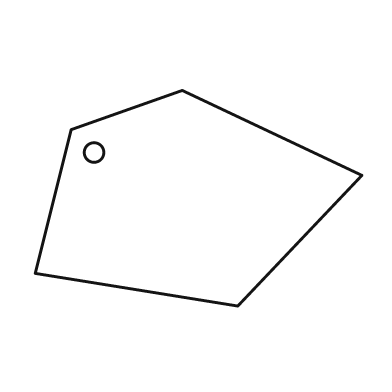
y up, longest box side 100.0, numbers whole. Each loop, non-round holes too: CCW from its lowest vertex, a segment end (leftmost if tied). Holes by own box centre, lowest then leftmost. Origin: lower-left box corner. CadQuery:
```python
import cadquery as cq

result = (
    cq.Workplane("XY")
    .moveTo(62.0, 0.0)
    .lineTo(100.0, 40.0)
    .lineTo(45.0, 66.0)
    .lineTo(11.0, 54.0)
    .lineTo(0.0, 10.0)
    .close()
    .moveTo(18.0, 47.0)
    .circle(3.0)
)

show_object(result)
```